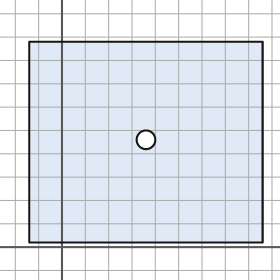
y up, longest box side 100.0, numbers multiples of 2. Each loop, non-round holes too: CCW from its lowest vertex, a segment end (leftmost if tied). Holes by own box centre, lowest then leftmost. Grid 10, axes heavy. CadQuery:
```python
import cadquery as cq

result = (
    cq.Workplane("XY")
    .moveTo(-14.0, 2.0)
    .lineTo(86.0, 2.0)
    .lineTo(86.0, 88.0)
    .lineTo(-14.0, 88.0)
    .close()
    .moveTo(36.0, 46.0)
    .circle(4.0)
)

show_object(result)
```